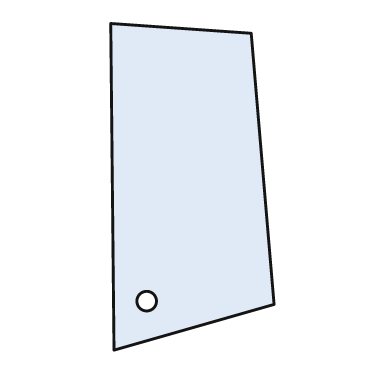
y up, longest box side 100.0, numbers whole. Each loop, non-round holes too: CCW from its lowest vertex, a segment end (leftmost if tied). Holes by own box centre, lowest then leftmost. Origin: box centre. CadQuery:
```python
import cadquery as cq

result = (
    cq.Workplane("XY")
    .moveTo(-24.0, -50.0)
    .lineTo(25.0, -36.0)
    .lineTo(18.0, 47.0)
    .lineTo(-25.0, 50.0)
    .close()
    .moveTo(-14.0, -35.0)
    .circle(3.0)
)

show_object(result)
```